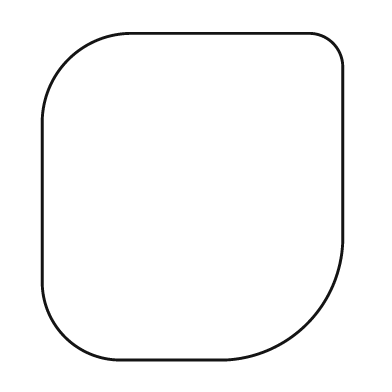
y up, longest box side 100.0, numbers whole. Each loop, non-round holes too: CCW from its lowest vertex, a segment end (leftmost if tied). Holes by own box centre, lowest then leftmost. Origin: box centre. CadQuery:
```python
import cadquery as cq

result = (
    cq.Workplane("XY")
    .moveTo(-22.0, -50.0)
    .lineTo(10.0, -50.0)
    .threePointArc((35.0, -39.0), (46.0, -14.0))
    .lineTo(46.0, 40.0)
    .threePointArc((43.0, 47.0), (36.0, 50.0))
    .lineTo(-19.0, 50.0)
    .threePointArc((-38.0, 42.0), (-46.0, 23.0))
    .lineTo(-46.0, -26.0)
    .threePointArc((-39.0, -43.0), (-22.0, -50.0))
    .close()
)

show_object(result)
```